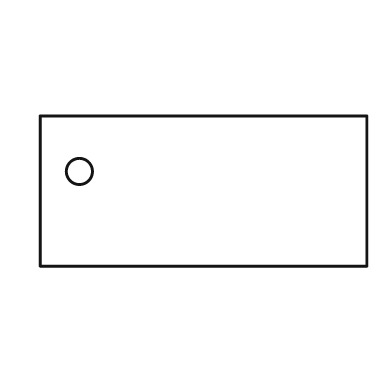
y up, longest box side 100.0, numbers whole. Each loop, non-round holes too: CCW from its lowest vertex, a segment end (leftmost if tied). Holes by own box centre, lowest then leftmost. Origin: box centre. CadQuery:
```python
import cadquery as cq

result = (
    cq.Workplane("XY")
    .moveTo(-50.0, -23.0)
    .lineTo(50.0, -23.0)
    .lineTo(50.0, 23.0)
    .lineTo(-50.0, 23.0)
    .close()
    .moveTo(-38.0, 6.0)
    .circle(4.0)
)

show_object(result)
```